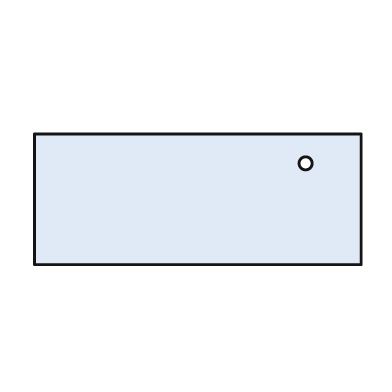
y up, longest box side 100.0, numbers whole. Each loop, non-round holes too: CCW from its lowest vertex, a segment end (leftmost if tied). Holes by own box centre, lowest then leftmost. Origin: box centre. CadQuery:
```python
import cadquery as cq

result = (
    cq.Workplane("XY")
    .moveTo(-50.0, -20.0)
    .lineTo(50.0, -20.0)
    .lineTo(50.0, 20.0)
    .lineTo(-50.0, 20.0)
    .close()
    .moveTo(33.0, 11.0)
    .circle(2.0)
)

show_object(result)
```